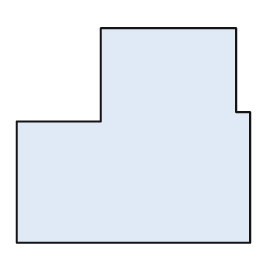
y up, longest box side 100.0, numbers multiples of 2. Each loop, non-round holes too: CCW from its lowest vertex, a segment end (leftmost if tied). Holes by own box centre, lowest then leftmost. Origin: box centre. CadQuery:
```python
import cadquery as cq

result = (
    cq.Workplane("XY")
    .moveTo(-50.0, -46.0)
    .lineTo(50.0, -46.0)
    .lineTo(50.0, 10.0)
    .lineTo(44.0, 10.0)
    .lineTo(44.0, 46.0)
    .lineTo(-14.0, 46.0)
    .lineTo(-14.0, 6.0)
    .lineTo(-50.0, 6.0)
    .close()
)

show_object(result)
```